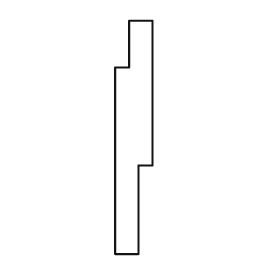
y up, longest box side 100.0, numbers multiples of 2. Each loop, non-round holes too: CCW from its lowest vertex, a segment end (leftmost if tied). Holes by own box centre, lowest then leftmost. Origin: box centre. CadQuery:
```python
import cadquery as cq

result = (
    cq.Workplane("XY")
    .moveTo(-8.0, -50.0)
    .lineTo(2.0, -50.0)
    .lineTo(2.0, -12.0)
    .lineTo(8.0, -12.0)
    .lineTo(8.0, 50.0)
    .lineTo(-2.0, 50.0)
    .lineTo(-2.0, 30.0)
    .lineTo(-8.0, 30.0)
    .close()
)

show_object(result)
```